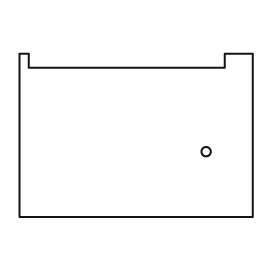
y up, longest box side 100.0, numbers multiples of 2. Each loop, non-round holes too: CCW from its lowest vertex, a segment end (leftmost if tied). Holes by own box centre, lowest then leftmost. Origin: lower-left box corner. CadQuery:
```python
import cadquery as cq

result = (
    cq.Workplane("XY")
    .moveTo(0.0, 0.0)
    .lineTo(100.0, 0.0)
    .lineTo(100.0, 70.0)
    .lineTo(88.0, 70.0)
    .lineTo(88.0, 64.0)
    .lineTo(4.0, 64.0)
    .lineTo(4.0, 70.0)
    .lineTo(0.0, 70.0)
    .close()
    .moveTo(80.0, 28.0)
    .circle(2.0)
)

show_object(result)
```